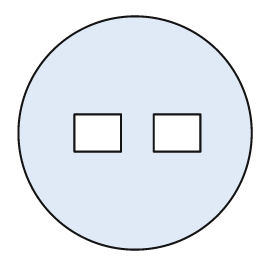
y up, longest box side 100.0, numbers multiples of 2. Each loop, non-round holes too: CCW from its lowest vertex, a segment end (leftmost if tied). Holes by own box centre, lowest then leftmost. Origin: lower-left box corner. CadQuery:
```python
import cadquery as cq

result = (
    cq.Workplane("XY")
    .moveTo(50.0, 50.0)
    .circle(50.0)
    .moveTo(24.0, 42.0)
    .lineTo(44.0, 42.0)
    .lineTo(44.0, 58.0)
    .lineTo(24.0, 58.0)
    .close()
    .moveTo(58.0, 42.0)
    .lineTo(78.0, 42.0)
    .lineTo(78.0, 58.0)
    .lineTo(58.0, 58.0)
    .close()
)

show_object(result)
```